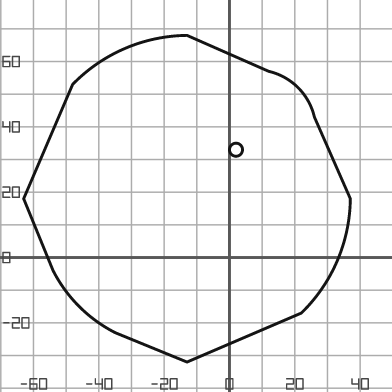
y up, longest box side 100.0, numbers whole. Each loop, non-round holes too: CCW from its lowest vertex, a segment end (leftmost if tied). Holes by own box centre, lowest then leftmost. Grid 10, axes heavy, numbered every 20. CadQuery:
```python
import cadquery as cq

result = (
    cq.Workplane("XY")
    .moveTo(-13.0, -32.0)
    .lineTo(22.0, -17.0)
    .threePointArc((33.0, -1.0), (37.0, 18.0))
    .lineTo(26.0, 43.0)
    .threePointArc((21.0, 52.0), (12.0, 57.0))
    .lineTo(-13.0, 68.0)
    .threePointArc((-32.0, 64.0), (-48.0, 53.0))
    .lineTo(-63.0, 18.0)
    .lineTo(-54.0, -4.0)
    .threePointArc((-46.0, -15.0), (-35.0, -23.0))
    .close()
    .moveTo(2.0, 33.0)
    .circle(2.0)
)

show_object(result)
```